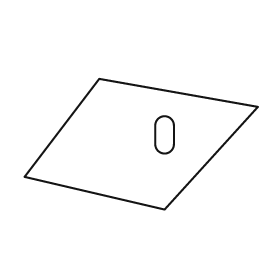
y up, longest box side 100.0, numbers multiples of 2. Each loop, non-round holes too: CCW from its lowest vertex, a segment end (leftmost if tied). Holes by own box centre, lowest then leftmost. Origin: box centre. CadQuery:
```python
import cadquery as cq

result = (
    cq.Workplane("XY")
    .moveTo(10.0, -28.0)
    .lineTo(50.0, 16.0)
    .lineTo(-18.0, 28.0)
    .lineTo(-50.0, -14.0)
    .close()
    .moveTo(6.0, 0.0)
    .threePointArc((10.0, -4.0), (14.0, 0.0))
    .lineTo(14.0, 8.0)
    .threePointArc((10.0, 12.0), (6.0, 8.0))
    .close()
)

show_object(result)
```